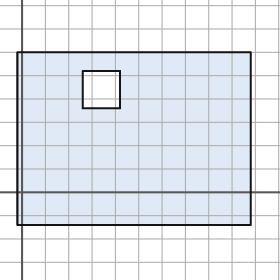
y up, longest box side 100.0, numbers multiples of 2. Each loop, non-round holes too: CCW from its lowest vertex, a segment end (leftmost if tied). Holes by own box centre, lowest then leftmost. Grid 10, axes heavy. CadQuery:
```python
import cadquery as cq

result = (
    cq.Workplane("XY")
    .moveTo(-2.0, -14.0)
    .lineTo(98.0, -14.0)
    .lineTo(98.0, 60.0)
    .lineTo(-2.0, 60.0)
    .close()
    .moveTo(26.0, 36.0)
    .lineTo(42.0, 36.0)
    .lineTo(42.0, 52.0)
    .lineTo(26.0, 52.0)
    .close()
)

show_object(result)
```